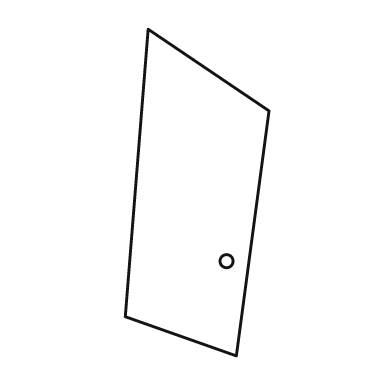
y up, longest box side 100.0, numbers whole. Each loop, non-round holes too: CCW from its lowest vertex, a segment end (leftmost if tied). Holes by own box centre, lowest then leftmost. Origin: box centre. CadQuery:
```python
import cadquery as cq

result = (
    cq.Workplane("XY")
    .moveTo(12.0, -50.0)
    .lineTo(22.0, 25.0)
    .lineTo(-15.0, 50.0)
    .lineTo(-22.0, -38.0)
    .close()
    .moveTo(9.0, -21.0)
    .circle(2.0)
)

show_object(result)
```